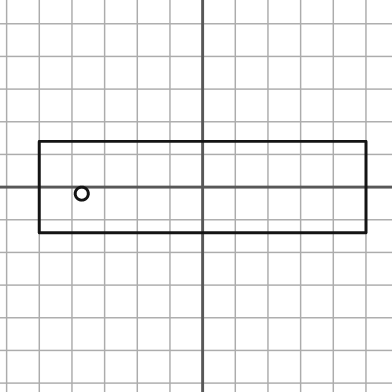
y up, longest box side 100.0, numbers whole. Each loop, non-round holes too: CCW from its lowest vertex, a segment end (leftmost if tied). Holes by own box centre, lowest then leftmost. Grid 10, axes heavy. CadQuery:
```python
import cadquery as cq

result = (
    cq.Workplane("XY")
    .moveTo(-50.0, -14.0)
    .lineTo(50.0, -14.0)
    .lineTo(50.0, 14.0)
    .lineTo(-50.0, 14.0)
    .close()
    .moveTo(-37.0, -2.0)
    .circle(2.0)
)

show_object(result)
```